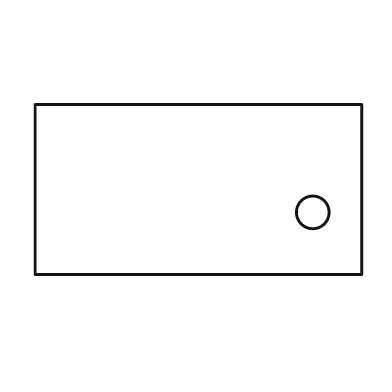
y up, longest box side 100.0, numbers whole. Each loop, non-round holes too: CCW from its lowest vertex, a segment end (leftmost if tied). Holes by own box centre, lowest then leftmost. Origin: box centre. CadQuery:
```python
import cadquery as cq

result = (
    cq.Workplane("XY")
    .moveTo(-50.0, -26.0)
    .lineTo(50.0, -26.0)
    .lineTo(50.0, 26.0)
    .lineTo(-50.0, 26.0)
    .close()
    .moveTo(35.0, -7.0)
    .circle(5.0)
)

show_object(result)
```